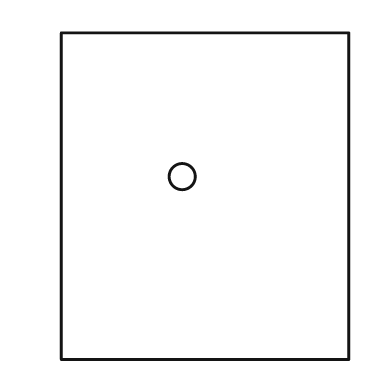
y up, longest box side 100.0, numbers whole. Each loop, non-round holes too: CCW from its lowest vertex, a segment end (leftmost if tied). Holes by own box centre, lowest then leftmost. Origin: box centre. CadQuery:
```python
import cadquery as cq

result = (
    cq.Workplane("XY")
    .moveTo(-44.0, -50.0)
    .lineTo(44.0, -50.0)
    .lineTo(44.0, 50.0)
    .lineTo(-44.0, 50.0)
    .close()
    .moveTo(-7.0, 6.0)
    .circle(4.0)
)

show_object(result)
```